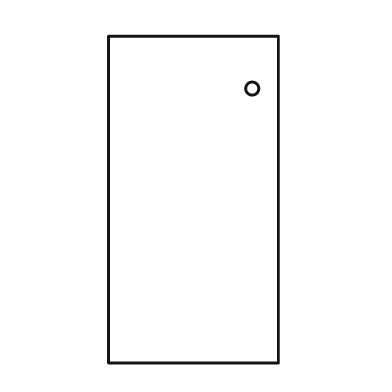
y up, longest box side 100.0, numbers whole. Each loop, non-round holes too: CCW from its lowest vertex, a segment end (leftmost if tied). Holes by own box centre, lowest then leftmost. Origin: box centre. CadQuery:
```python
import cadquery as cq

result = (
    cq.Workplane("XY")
    .moveTo(-26.0, -50.0)
    .lineTo(26.0, -50.0)
    .lineTo(26.0, 50.0)
    .lineTo(-26.0, 50.0)
    .close()
    .moveTo(18.0, 34.0)
    .circle(2.0)
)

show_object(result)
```